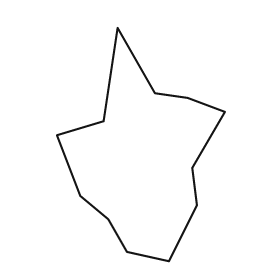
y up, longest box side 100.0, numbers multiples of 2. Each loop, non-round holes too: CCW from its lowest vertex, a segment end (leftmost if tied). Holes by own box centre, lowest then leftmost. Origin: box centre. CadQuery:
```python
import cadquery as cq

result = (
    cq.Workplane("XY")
    .moveTo(12.0, -50.0)
    .lineTo(24.0, -26.0)
    .lineTo(22.0, -10.0)
    .lineTo(36.0, 14.0)
    .lineTo(20.0, 20.0)
    .lineTo(6.0, 22.0)
    .lineTo(-10.0, 50.0)
    .lineTo(-16.0, 10.0)
    .lineTo(-36.0, 4.0)
    .lineTo(-26.0, -22.0)
    .lineTo(-14.0, -32.0)
    .lineTo(-6.0, -46.0)
    .close()
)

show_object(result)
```